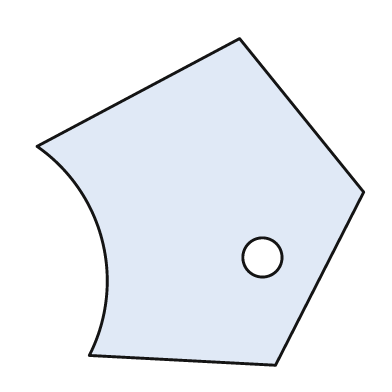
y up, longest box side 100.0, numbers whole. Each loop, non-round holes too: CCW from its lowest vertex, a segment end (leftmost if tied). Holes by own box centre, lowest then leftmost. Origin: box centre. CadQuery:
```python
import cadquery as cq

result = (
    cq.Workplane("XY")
    .moveTo(23.0, -50.0)
    .lineTo(50.0, 3.0)
    .lineTo(12.0, 50.0)
    .lineTo(-50.0, 17.0)
    .threePointArc((-30.0, -12.0), (-34.0, -47.0))
    .close()
    .moveTo(19.0, -17.0)
    .circle(6.0)
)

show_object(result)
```